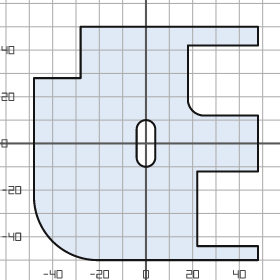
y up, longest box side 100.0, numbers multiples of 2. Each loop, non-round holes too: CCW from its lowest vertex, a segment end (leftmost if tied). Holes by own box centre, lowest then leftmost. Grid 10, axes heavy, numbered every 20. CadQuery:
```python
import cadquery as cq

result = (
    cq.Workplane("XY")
    .moveTo(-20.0, -50.0)
    .lineTo(48.0, -50.0)
    .lineTo(48.0, -44.0)
    .lineTo(22.0, -44.0)
    .lineTo(22.0, -12.0)
    .lineTo(48.0, -12.0)
    .lineTo(48.0, 12.0)
    .lineTo(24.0, 12.0)
    .threePointArc((20.0, 14.0), (18.0, 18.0))
    .lineTo(18.0, 42.0)
    .lineTo(48.0, 42.0)
    .lineTo(48.0, 50.0)
    .lineTo(-28.0, 50.0)
    .lineTo(-28.0, 28.0)
    .lineTo(-48.0, 28.0)
    .lineTo(-48.0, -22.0)
    .threePointArc((-40.0, -42.0), (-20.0, -50.0))
    .close()
    .moveTo(-4.0, -6.0)
    .threePointArc((0.0, -10.0), (4.0, -6.0))
    .lineTo(4.0, 6.0)
    .threePointArc((0.0, 10.0), (-4.0, 6.0))
    .close()
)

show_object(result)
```